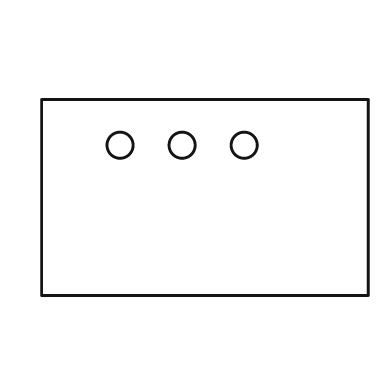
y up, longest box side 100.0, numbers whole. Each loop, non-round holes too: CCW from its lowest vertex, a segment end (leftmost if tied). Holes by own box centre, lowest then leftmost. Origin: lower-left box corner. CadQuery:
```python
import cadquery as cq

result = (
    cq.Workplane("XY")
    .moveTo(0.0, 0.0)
    .lineTo(100.0, 0.0)
    .lineTo(100.0, 60.0)
    .lineTo(0.0, 60.0)
    .close()
    .moveTo(24.0, 46.0)
    .circle(4.0)
    .moveTo(43.0, 46.0)
    .circle(4.0)
    .moveTo(62.0, 46.0)
    .circle(4.0)
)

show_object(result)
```